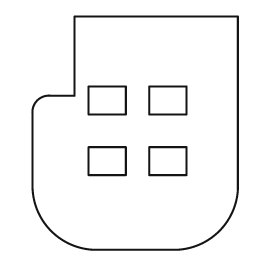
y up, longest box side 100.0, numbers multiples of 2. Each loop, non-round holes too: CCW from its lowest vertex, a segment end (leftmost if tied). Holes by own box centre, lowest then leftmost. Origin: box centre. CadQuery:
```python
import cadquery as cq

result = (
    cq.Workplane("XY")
    .moveTo(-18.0, -50.0)
    .lineTo(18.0, -50.0)
    .threePointArc((36.0, -42.0), (44.0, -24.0))
    .lineTo(44.0, 50.0)
    .lineTo(-26.0, 50.0)
    .lineTo(-26.0, 16.0)
    .lineTo(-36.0, 16.0)
    .threePointArc((-42.0, 14.0), (-44.0, 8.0))
    .lineTo(-44.0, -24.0)
    .threePointArc((-36.0, -42.0), (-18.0, -50.0))
    .close()
    .moveTo(-20.0, -18.0)
    .lineTo(-4.0, -18.0)
    .lineTo(-4.0, -6.0)
    .lineTo(-20.0, -6.0)
    .close()
    .moveTo(6.0, -18.0)
    .lineTo(22.0, -18.0)
    .lineTo(22.0, -6.0)
    .lineTo(6.0, -6.0)
    .close()
    .moveTo(-20.0, 8.0)
    .lineTo(-4.0, 8.0)
    .lineTo(-4.0, 20.0)
    .lineTo(-20.0, 20.0)
    .close()
    .moveTo(6.0, 8.0)
    .lineTo(22.0, 8.0)
    .lineTo(22.0, 20.0)
    .lineTo(6.0, 20.0)
    .close()
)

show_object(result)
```